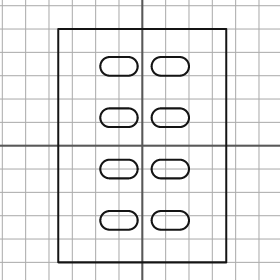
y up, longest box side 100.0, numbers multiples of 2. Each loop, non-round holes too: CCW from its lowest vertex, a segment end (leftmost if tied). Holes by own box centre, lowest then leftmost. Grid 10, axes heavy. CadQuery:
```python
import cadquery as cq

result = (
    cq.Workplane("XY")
    .moveTo(-36.0, -50.0)
    .lineTo(36.0, -50.0)
    .lineTo(36.0, 50.0)
    .lineTo(-36.0, 50.0)
    .close()
    .moveTo(-14.0, -36.0)
    .lineTo(-6.0, -36.0)
    .threePointArc((-2.0, -32.0), (-6.0, -28.0))
    .lineTo(-14.0, -28.0)
    .threePointArc((-18.0, -32.0), (-14.0, -36.0))
    .close()
    .moveTo(8.0, -36.0)
    .lineTo(16.0, -36.0)
    .threePointArc((20.0, -32.0), (16.0, -28.0))
    .lineTo(8.0, -28.0)
    .threePointArc((4.0, -32.0), (8.0, -36.0))
    .close()
    .moveTo(-14.0, -14.0)
    .lineTo(-6.0, -14.0)
    .threePointArc((-2.0, -10.0), (-6.0, -6.0))
    .lineTo(-14.0, -6.0)
    .threePointArc((-18.0, -10.0), (-14.0, -14.0))
    .close()
    .moveTo(8.0, -14.0)
    .lineTo(16.0, -14.0)
    .threePointArc((20.0, -10.0), (16.0, -6.0))
    .lineTo(8.0, -6.0)
    .threePointArc((4.0, -10.0), (8.0, -14.0))
    .close()
    .moveTo(-14.0, 8.0)
    .lineTo(-6.0, 8.0)
    .threePointArc((-2.0, 12.0), (-6.0, 16.0))
    .lineTo(-14.0, 16.0)
    .threePointArc((-18.0, 12.0), (-14.0, 8.0))
    .close()
    .moveTo(8.0, 8.0)
    .lineTo(16.0, 8.0)
    .threePointArc((20.0, 12.0), (16.0, 16.0))
    .lineTo(8.0, 16.0)
    .threePointArc((4.0, 12.0), (8.0, 8.0))
    .close()
    .moveTo(-14.0, 30.0)
    .lineTo(-6.0, 30.0)
    .threePointArc((-2.0, 34.0), (-6.0, 38.0))
    .lineTo(-14.0, 38.0)
    .threePointArc((-18.0, 34.0), (-14.0, 30.0))
    .close()
    .moveTo(8.0, 30.0)
    .lineTo(16.0, 30.0)
    .threePointArc((20.0, 34.0), (16.0, 38.0))
    .lineTo(8.0, 38.0)
    .threePointArc((4.0, 34.0), (8.0, 30.0))
    .close()
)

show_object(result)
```